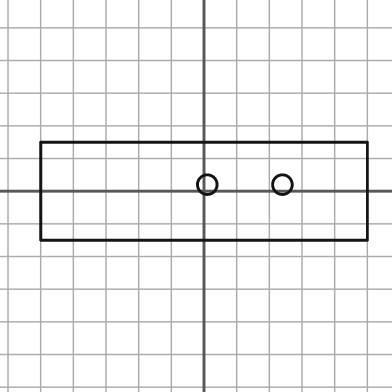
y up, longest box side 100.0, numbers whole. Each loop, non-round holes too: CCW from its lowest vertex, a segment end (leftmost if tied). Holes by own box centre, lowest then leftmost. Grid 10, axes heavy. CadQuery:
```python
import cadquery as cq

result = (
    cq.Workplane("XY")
    .moveTo(-50.0, -15.0)
    .lineTo(50.0, -15.0)
    .lineTo(50.0, 15.0)
    .lineTo(-50.0, 15.0)
    .close()
    .moveTo(1.0, 2.0)
    .circle(3.0)
    .moveTo(24.0, 2.0)
    .circle(3.0)
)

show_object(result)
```